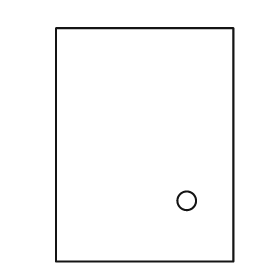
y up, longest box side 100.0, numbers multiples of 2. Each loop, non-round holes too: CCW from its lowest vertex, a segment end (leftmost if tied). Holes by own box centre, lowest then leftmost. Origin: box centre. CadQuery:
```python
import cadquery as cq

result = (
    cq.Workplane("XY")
    .moveTo(-38.0, -50.0)
    .lineTo(38.0, -50.0)
    .lineTo(38.0, 50.0)
    .lineTo(-38.0, 50.0)
    .close()
    .moveTo(18.0, -24.0)
    .circle(4.0)
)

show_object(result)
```